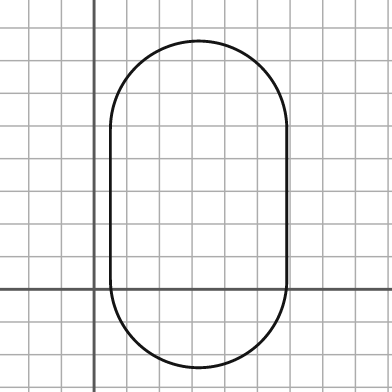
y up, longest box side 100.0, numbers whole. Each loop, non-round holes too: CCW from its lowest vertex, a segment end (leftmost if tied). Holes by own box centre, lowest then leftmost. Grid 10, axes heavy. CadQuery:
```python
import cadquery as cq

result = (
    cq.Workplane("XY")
    .moveTo(5.0, 3.0)
    .threePointArc((32.0, -24.0), (59.0, 3.0))
    .lineTo(59.0, 49.0)
    .threePointArc((32.0, 76.0), (5.0, 49.0))
    .close()
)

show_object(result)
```